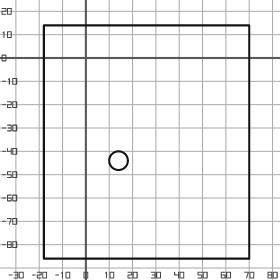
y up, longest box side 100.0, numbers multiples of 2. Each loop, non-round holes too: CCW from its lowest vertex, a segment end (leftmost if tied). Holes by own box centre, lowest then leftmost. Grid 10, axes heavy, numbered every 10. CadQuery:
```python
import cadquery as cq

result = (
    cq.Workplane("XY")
    .moveTo(-18.0, -86.0)
    .lineTo(70.0, -86.0)
    .lineTo(70.0, 14.0)
    .lineTo(-18.0, 14.0)
    .close()
    .moveTo(14.0, -44.0)
    .circle(4.0)
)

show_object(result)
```